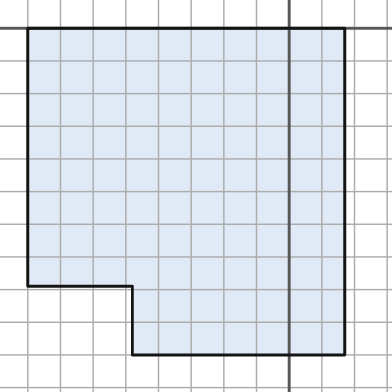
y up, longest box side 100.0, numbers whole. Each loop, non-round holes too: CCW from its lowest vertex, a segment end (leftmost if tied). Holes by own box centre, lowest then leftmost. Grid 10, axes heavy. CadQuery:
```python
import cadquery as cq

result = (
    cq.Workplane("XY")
    .moveTo(-48.0, -100.0)
    .lineTo(17.0, -100.0)
    .lineTo(17.0, 0.0)
    .lineTo(-80.0, 0.0)
    .lineTo(-80.0, -79.0)
    .lineTo(-48.0, -79.0)
    .close()
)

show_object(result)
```